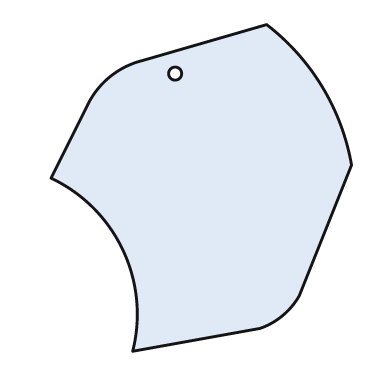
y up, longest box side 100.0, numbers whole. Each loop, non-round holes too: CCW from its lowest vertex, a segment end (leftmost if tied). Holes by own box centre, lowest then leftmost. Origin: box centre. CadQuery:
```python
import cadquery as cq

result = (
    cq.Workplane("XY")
    .moveTo(-21.0, -50.0)
    .lineTo(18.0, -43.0)
    .threePointArc((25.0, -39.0), (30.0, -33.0))
    .lineTo(46.0, 7.0)
    .threePointArc((37.0, 31.0), (20.0, 50.0))
    .lineTo(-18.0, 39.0)
    .threePointArc((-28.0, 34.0), (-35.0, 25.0))
    .lineTo(-46.0, 3.0)
    .threePointArc((-24.0, -19.0), (-21.0, -50.0))
    .close()
    .moveTo(-8.0, 35.0)
    .circle(2.0)
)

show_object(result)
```